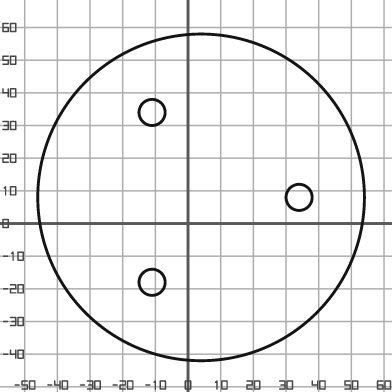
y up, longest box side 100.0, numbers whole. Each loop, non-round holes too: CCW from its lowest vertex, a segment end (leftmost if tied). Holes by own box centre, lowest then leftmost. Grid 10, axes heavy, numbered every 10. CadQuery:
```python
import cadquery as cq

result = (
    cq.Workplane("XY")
    .moveTo(4.0, 8.0)
    .circle(50.0)
    .moveTo(-11.0, -18.0)
    .circle(4.0)
    .moveTo(34.0, 8.0)
    .circle(4.0)
    .moveTo(-11.0, 34.0)
    .circle(4.0)
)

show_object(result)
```